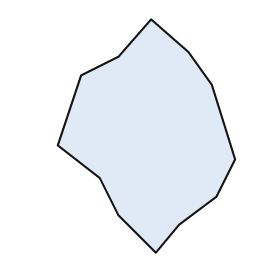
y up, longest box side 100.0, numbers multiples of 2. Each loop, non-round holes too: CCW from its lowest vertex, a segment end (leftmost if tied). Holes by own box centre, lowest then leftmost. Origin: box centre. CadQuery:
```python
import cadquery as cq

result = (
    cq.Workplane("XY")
    .moveTo(4.0, -50.0)
    .lineTo(14.0, -38.0)
    .lineTo(30.0, -26.0)
    .lineTo(38.0, -10.0)
    .lineTo(28.0, 22.0)
    .lineTo(18.0, 36.0)
    .lineTo(2.0, 50.0)
    .lineTo(-12.0, 34.0)
    .lineTo(-28.0, 26.0)
    .lineTo(-38.0, -4.0)
    .lineTo(-20.0, -18.0)
    .lineTo(-12.0, -34.0)
    .close()
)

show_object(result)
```